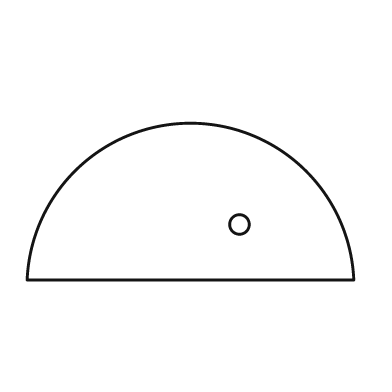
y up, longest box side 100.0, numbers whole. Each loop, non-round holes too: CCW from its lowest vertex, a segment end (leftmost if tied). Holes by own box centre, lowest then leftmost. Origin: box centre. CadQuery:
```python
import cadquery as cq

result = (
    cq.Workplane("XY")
    .moveTo(-50.0, -24.0)
    .lineTo(50.0, -24.0)
    .threePointArc((0.0, 24.0), (-50.0, -24.0))
    .close()
    .moveTo(15.0, -7.0)
    .circle(3.0)
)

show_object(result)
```